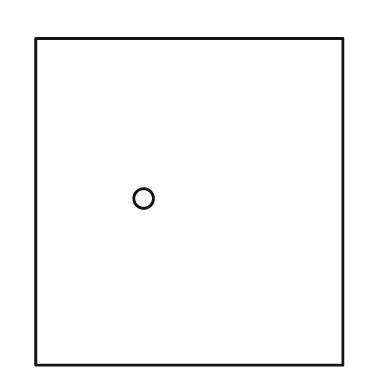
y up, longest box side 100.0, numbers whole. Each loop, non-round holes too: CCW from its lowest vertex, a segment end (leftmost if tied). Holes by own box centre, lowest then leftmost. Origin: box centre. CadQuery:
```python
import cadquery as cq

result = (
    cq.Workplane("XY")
    .moveTo(-47.0, -50.0)
    .lineTo(47.0, -50.0)
    .lineTo(47.0, 50.0)
    .lineTo(-47.0, 50.0)
    .close()
    .moveTo(-14.0, 1.0)
    .circle(3.0)
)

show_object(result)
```